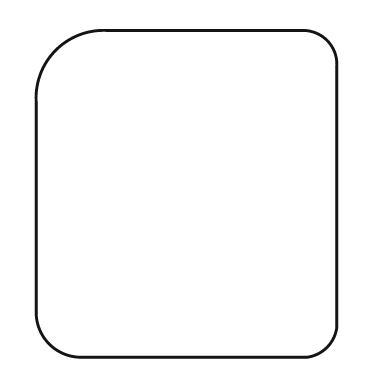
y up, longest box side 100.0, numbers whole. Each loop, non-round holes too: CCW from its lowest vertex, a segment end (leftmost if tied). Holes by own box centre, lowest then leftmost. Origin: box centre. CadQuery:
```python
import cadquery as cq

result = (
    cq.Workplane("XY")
    .moveTo(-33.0, -50.0)
    .lineTo(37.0, -50.0)
    .threePointArc((43.0, -47.0), (46.0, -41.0))
    .lineTo(46.0, 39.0)
    .threePointArc((43.0, 47.0), (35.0, 50.0))
    .lineTo(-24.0, 50.0)
    .threePointArc((-40.0, 44.0), (-46.0, 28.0))
    .lineTo(-46.0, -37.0)
    .threePointArc((-42.0, -46.0), (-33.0, -50.0))
    .close()
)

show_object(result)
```